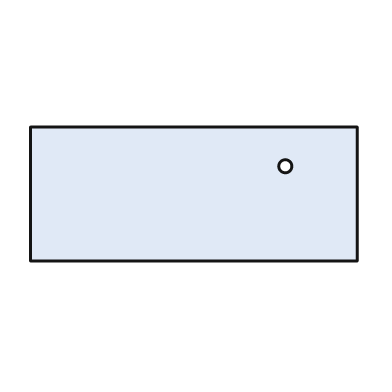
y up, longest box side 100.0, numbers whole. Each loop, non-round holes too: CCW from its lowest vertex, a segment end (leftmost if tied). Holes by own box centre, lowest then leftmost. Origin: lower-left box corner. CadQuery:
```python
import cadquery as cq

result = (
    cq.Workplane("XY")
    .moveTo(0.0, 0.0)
    .lineTo(100.0, 0.0)
    .lineTo(100.0, 41.0)
    .lineTo(0.0, 41.0)
    .close()
    .moveTo(78.0, 29.0)
    .circle(2.0)
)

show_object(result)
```